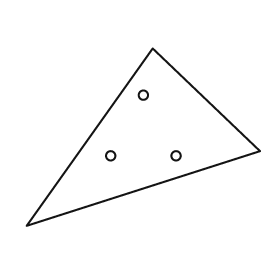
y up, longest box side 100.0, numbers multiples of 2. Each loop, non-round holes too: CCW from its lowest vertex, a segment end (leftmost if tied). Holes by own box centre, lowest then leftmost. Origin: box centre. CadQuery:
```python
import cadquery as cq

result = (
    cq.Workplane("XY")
    .moveTo(-50.0, -38.0)
    .lineTo(50.0, -6.0)
    .lineTo(4.0, 38.0)
    .close()
    .moveTo(-14.0, -8.0)
    .circle(2.0)
    .moveTo(14.0, -8.0)
    .circle(2.0)
    .moveTo(0.0, 18.0)
    .circle(2.0)
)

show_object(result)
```